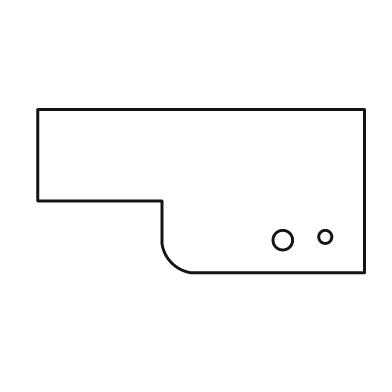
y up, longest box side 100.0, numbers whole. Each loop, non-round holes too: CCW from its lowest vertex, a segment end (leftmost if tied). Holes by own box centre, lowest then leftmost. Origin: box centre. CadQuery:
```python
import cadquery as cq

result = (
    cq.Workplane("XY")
    .moveTo(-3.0, -25.0)
    .lineTo(50.0, -25.0)
    .lineTo(50.0, 25.0)
    .lineTo(-50.0, 25.0)
    .lineTo(-50.0, -3.0)
    .lineTo(-12.0, -3.0)
    .lineTo(-12.0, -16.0)
    .threePointArc((-9.0, -22.0), (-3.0, -25.0))
    .close()
    .moveTo(25.0, -15.0)
    .circle(3.0)
    .moveTo(38.0, -14.0)
    .circle(2.0)
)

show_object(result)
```